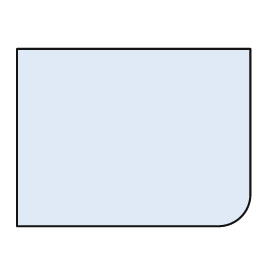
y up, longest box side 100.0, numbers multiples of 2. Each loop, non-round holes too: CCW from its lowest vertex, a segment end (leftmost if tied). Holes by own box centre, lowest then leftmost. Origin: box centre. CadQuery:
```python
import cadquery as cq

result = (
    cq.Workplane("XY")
    .moveTo(-50.0, -38.0)
    .lineTo(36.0, -38.0)
    .threePointArc((46.0, -34.0), (50.0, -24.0))
    .lineTo(50.0, 38.0)
    .lineTo(-50.0, 38.0)
    .close()
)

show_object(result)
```